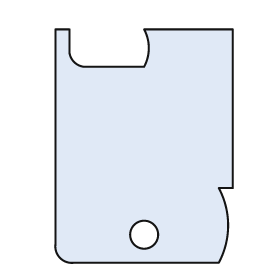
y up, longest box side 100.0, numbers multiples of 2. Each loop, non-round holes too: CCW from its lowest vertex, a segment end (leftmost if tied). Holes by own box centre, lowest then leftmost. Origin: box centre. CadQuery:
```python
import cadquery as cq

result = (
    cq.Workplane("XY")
    .moveTo(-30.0, -50.0)
    .lineTo(32.0, -50.0)
    .threePointArc((36.0, -34.0), (32.0, -18.0))
    .lineTo(38.0, -18.0)
    .lineTo(38.0, 50.0)
    .lineTo(0.0, 50.0)
    .threePointArc((2.0, 42.0), (0.0, 34.0))
    .lineTo(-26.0, 34.0)
    .threePointArc((-30.0, 36.0), (-32.0, 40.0))
    .lineTo(-32.0, 50.0)
    .lineTo(-38.0, 50.0)
    .lineTo(-38.0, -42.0)
    .threePointArc((-36.0, -48.0), (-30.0, -50.0))
    .close()
    .moveTo(0.0, -38.0)
    .circle(6.0)
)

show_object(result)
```